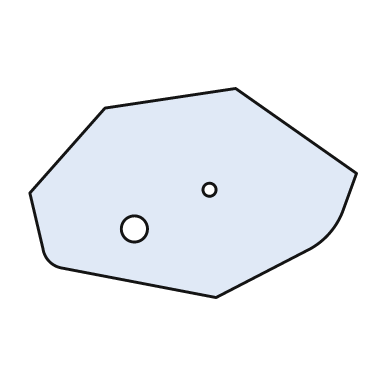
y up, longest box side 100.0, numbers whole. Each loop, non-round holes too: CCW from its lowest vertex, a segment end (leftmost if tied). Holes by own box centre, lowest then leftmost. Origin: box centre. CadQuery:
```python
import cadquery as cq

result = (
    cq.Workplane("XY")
    .moveTo(7.0, -32.0)
    .lineTo(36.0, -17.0)
    .threePointArc((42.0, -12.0), (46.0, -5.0))
    .lineTo(50.0, 6.0)
    .lineTo(13.0, 32.0)
    .lineTo(-27.0, 26.0)
    .lineTo(-50.0, 0.0)
    .lineTo(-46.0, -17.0)
    .threePointArc((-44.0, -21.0), (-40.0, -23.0))
    .close()
    .moveTo(-18.0, -11.0)
    .circle(4.0)
    .moveTo(5.0, 1.0)
    .circle(2.0)
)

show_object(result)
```